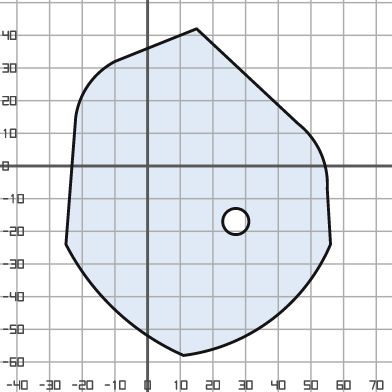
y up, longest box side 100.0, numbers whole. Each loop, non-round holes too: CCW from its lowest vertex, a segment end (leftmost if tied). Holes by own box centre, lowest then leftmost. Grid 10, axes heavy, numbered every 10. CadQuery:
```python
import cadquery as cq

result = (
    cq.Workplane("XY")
    .moveTo(11.0, -58.0)
    .threePointArc((38.0, -47.0), (56.0, -24.0))
    .lineTo(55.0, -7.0)
    .threePointArc((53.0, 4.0), (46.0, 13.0))
    .lineTo(15.0, 42.0)
    .lineTo(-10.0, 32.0)
    .threePointArc((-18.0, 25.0), (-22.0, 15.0))
    .lineTo(-25.0, -24.0)
    .threePointArc((-10.0, -44.0), (11.0, -58.0))
    .close()
    .moveTo(27.0, -17.0)
    .circle(4.0)
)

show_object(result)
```